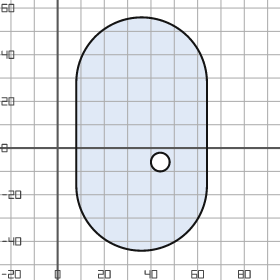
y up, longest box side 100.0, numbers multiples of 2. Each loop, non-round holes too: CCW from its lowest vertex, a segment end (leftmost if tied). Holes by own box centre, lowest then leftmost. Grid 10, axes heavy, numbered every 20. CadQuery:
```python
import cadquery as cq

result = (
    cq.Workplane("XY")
    .moveTo(8.0, -16.0)
    .threePointArc((36.0, -44.0), (64.0, -16.0))
    .lineTo(64.0, 28.0)
    .threePointArc((36.0, 56.0), (8.0, 28.0))
    .close()
    .moveTo(44.0, -6.0)
    .circle(4.0)
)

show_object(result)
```